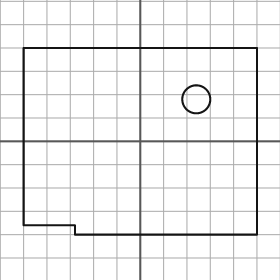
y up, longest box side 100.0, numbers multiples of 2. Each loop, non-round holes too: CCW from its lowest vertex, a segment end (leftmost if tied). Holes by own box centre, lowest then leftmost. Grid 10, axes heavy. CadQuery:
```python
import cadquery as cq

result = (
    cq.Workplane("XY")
    .moveTo(-28.0, -40.0)
    .lineTo(50.0, -40.0)
    .lineTo(50.0, 40.0)
    .lineTo(-50.0, 40.0)
    .lineTo(-50.0, -36.0)
    .lineTo(-28.0, -36.0)
    .close()
    .moveTo(24.0, 18.0)
    .circle(6.0)
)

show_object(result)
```